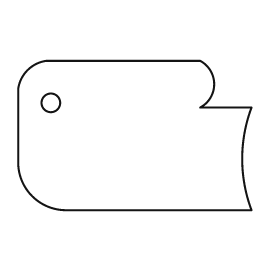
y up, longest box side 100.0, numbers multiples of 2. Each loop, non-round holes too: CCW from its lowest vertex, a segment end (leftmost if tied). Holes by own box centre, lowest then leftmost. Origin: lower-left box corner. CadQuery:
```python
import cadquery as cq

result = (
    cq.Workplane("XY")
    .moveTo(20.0, 0.0)
    .lineTo(100.0, 0.0)
    .threePointArc((96.0, 22.0), (100.0, 44.0))
    .lineTo(78.0, 44.0)
    .threePointArc((84.0, 54.0), (78.0, 64.0))
    .lineTo(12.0, 64.0)
    .threePointArc((4.0, 60.0), (0.0, 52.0))
    .lineTo(0.0, 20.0)
    .threePointArc((6.0, 6.0), (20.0, 0.0))
    .close()
    .moveTo(14.0, 46.0)
    .circle(4.0)
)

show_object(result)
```